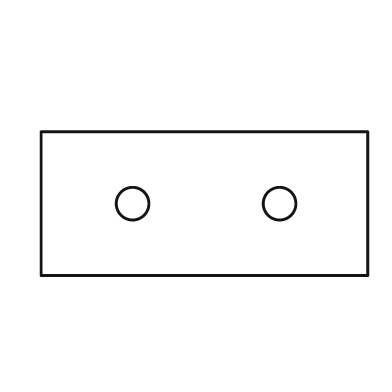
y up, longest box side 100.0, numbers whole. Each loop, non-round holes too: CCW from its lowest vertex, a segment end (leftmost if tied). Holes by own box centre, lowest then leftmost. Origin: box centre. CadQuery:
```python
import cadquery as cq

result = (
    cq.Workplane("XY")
    .moveTo(-50.0, -22.0)
    .lineTo(50.0, -22.0)
    .lineTo(50.0, 22.0)
    .lineTo(-50.0, 22.0)
    .close()
    .moveTo(-22.0, 0.0)
    .circle(5.0)
    .moveTo(23.0, 0.0)
    .circle(5.0)
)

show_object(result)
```